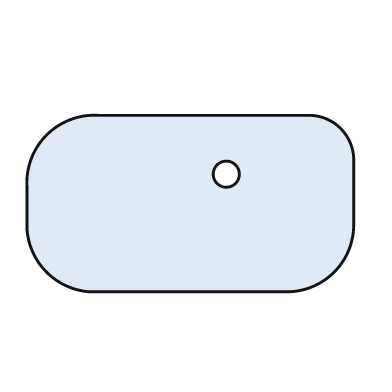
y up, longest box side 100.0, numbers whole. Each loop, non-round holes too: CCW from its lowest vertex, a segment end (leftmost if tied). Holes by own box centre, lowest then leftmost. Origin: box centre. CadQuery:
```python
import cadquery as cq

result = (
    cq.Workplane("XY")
    .moveTo(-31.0, -27.0)
    .lineTo(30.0, -27.0)
    .threePointArc((44.0, -21.0), (50.0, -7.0))
    .lineTo(50.0, 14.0)
    .threePointArc((46.0, 23.0), (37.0, 27.0))
    .lineTo(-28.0, 27.0)
    .threePointArc((-44.0, 21.0), (-50.0, 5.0))
    .lineTo(-50.0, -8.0)
    .threePointArc((-44.0, -21.0), (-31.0, -27.0))
    .close()
    .moveTo(11.0, 9.0)
    .circle(4.0)
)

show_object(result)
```